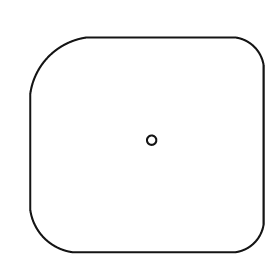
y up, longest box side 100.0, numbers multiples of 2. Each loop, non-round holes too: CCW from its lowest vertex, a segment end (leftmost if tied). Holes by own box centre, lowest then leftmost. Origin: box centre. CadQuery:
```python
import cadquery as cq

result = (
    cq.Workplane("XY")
    .moveTo(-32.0, -46.0)
    .lineTo(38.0, -46.0)
    .threePointArc((46.0, -42.0), (50.0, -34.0))
    .lineTo(50.0, 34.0)
    .threePointArc((46.0, 42.0), (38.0, 46.0))
    .lineTo(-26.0, 46.0)
    .threePointArc((-42.0, 38.0), (-50.0, 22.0))
    .lineTo(-50.0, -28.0)
    .threePointArc((-44.0, -40.0), (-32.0, -46.0))
    .close()
    .moveTo(2.0, 2.0)
    .circle(2.0)
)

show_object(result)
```